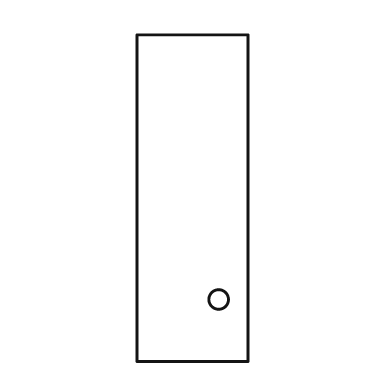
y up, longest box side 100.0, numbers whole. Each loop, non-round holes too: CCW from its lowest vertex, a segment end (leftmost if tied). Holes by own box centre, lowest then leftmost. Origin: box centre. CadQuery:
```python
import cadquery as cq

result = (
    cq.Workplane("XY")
    .moveTo(-17.0, -50.0)
    .lineTo(17.0, -50.0)
    .lineTo(17.0, 50.0)
    .lineTo(-17.0, 50.0)
    .close()
    .moveTo(8.0, -31.0)
    .circle(3.0)
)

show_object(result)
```